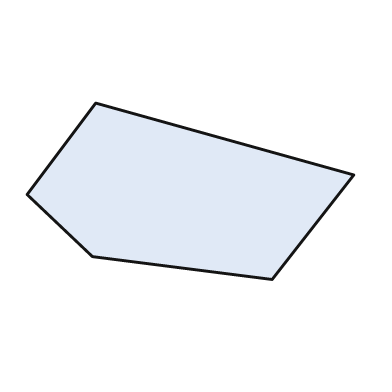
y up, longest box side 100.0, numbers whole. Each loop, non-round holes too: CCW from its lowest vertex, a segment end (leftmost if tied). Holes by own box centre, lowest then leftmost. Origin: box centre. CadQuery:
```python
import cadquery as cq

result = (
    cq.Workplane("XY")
    .moveTo(25.0, -27.0)
    .lineTo(50.0, 5.0)
    .lineTo(-29.0, 27.0)
    .lineTo(-50.0, -1.0)
    .lineTo(-30.0, -20.0)
    .close()
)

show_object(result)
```